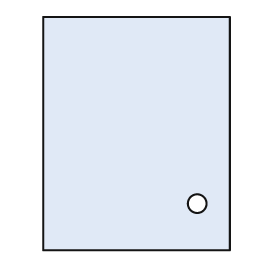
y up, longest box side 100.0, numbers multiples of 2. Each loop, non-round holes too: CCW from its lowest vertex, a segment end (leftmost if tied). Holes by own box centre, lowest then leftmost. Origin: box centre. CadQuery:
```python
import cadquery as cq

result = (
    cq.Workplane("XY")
    .moveTo(-40.0, -50.0)
    .lineTo(40.0, -50.0)
    .lineTo(40.0, 50.0)
    .lineTo(-40.0, 50.0)
    .close()
    .moveTo(26.0, -30.0)
    .circle(4.0)
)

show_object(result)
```